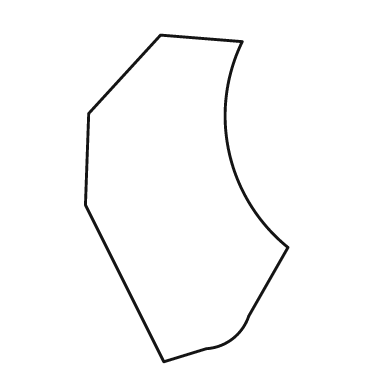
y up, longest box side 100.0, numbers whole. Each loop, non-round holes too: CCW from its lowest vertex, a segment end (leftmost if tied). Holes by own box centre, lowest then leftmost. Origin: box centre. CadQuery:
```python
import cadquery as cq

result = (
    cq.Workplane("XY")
    .moveTo(-7.0, -50.0)
    .lineTo(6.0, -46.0)
    .threePointArc((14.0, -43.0), (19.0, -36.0))
    .lineTo(31.0, -15.0)
    .threePointArc((13.0, 14.0), (17.0, 48.0))
    .lineTo(-8.0, 50.0)
    .lineTo(-30.0, 26.0)
    .lineTo(-31.0, -2.0)
    .close()
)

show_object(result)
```